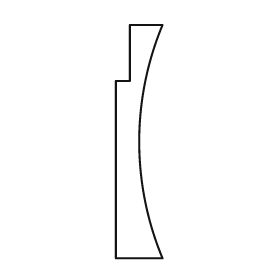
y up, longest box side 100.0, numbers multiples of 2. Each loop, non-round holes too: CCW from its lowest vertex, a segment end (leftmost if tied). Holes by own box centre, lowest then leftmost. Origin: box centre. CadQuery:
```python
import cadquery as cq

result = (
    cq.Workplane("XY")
    .moveTo(-10.0, -50.0)
    .lineTo(10.0, -50.0)
    .threePointArc((0.0, 0.0), (10.0, 50.0))
    .lineTo(-4.0, 50.0)
    .lineTo(-4.0, 26.0)
    .lineTo(-10.0, 26.0)
    .close()
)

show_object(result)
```